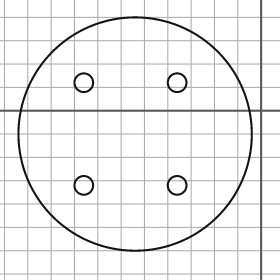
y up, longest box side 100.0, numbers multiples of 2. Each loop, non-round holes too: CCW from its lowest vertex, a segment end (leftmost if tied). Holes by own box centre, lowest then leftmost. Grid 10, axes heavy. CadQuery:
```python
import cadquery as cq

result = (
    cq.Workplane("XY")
    .moveTo(-54.0, -10.0)
    .circle(50.0)
    .moveTo(-76.0, -32.0)
    .circle(4.0)
    .moveTo(-36.0, -32.0)
    .circle(4.0)
    .moveTo(-76.0, 12.0)
    .circle(4.0)
    .moveTo(-36.0, 12.0)
    .circle(4.0)
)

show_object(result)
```